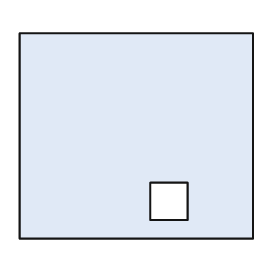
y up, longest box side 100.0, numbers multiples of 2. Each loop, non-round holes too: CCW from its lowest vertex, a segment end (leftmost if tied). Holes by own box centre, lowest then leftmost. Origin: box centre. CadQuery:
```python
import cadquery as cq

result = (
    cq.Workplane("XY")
    .moveTo(-50.0, -44.0)
    .lineTo(50.0, -44.0)
    .lineTo(50.0, 44.0)
    .lineTo(-50.0, 44.0)
    .close()
    .moveTo(6.0, -36.0)
    .lineTo(22.0, -36.0)
    .lineTo(22.0, -20.0)
    .lineTo(6.0, -20.0)
    .close()
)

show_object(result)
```